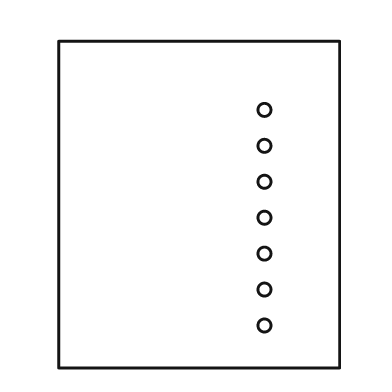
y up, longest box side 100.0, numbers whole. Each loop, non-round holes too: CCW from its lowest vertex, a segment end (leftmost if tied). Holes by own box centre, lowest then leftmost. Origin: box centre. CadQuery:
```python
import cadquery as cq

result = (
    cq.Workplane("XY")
    .moveTo(-43.0, -50.0)
    .lineTo(43.0, -50.0)
    .lineTo(43.0, 50.0)
    .lineTo(-43.0, 50.0)
    .close()
    .moveTo(20.0, -37.0)
    .circle(2.0)
    .moveTo(20.0, -26.0)
    .circle(2.0)
    .moveTo(20.0, -15.0)
    .circle(2.0)
    .moveTo(20.0, -4.0)
    .circle(2.0)
    .moveTo(20.0, 7.0)
    .circle(2.0)
    .moveTo(20.0, 18.0)
    .circle(2.0)
    .moveTo(20.0, 29.0)
    .circle(2.0)
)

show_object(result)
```